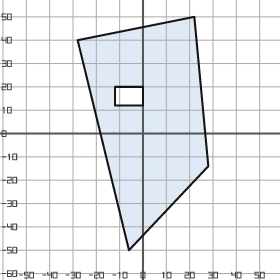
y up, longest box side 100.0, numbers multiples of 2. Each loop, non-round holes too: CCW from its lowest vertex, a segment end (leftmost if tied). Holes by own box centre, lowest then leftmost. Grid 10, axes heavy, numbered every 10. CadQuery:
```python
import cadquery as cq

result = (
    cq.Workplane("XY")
    .moveTo(-6.0, -50.0)
    .lineTo(28.0, -14.0)
    .lineTo(22.0, 50.0)
    .lineTo(-28.0, 40.0)
    .close()
    .moveTo(-12.0, 12.0)
    .lineTo(0.0, 12.0)
    .lineTo(0.0, 20.0)
    .lineTo(-12.0, 20.0)
    .close()
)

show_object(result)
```